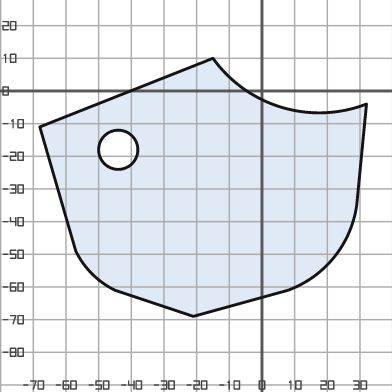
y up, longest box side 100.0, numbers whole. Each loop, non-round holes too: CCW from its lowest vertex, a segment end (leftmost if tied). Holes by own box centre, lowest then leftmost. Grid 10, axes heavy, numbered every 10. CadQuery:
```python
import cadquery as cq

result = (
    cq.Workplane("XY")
    .moveTo(-21.0, -69.0)
    .lineTo(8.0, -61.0)
    .threePointArc((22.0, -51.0), (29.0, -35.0))
    .lineTo(32.0, -4.0)
    .threePointArc((6.0, -5.0), (-15.0, 10.0))
    .lineTo(-68.0, -11.0)
    .lineTo(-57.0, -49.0)
    .threePointArc((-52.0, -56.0), (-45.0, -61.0))
    .close()
    .moveTo(-44.0, -18.0)
    .circle(6.0)
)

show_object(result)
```